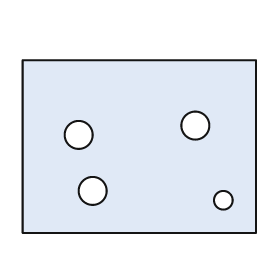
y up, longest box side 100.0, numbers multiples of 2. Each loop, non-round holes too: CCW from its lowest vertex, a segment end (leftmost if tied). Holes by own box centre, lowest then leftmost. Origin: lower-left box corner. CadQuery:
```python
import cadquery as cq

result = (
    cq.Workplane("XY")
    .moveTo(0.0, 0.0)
    .lineTo(100.0, 0.0)
    .lineTo(100.0, 74.0)
    .lineTo(0.0, 74.0)
    .close()
    .moveTo(86.0, 14.0)
    .circle(4.0)
    .moveTo(30.0, 18.0)
    .circle(6.0)
    .moveTo(24.0, 42.0)
    .circle(6.0)
    .moveTo(74.0, 46.0)
    .circle(6.0)
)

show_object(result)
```